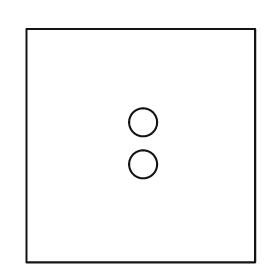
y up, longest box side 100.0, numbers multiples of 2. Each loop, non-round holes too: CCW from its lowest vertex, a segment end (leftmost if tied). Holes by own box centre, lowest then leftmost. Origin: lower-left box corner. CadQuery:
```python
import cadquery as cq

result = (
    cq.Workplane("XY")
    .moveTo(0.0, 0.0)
    .lineTo(98.0, 0.0)
    .lineTo(98.0, 100.0)
    .lineTo(0.0, 100.0)
    .close()
    .moveTo(50.0, 42.0)
    .circle(6.0)
    .moveTo(50.0, 60.0)
    .circle(6.0)
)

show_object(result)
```